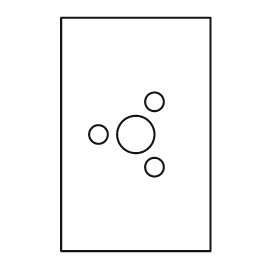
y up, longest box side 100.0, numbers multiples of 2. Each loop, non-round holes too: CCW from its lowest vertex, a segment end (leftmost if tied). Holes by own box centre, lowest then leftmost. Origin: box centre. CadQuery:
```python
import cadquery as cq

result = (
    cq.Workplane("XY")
    .moveTo(-32.0, -50.0)
    .lineTo(32.0, -50.0)
    .lineTo(32.0, 50.0)
    .lineTo(-32.0, 50.0)
    .close()
    .moveTo(8.0, -14.0)
    .circle(4.0)
    .moveTo(-16.0, 0.0)
    .circle(4.0)
    .moveTo(0.0, 0.0)
    .circle(8.0)
    .moveTo(8.0, 14.0)
    .circle(4.0)
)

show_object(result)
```